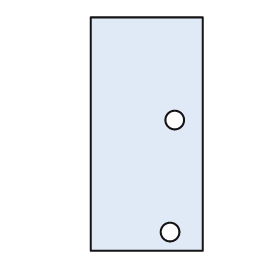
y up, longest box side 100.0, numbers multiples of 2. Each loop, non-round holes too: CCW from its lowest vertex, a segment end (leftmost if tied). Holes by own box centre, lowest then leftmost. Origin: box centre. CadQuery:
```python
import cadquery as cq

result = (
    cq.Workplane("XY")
    .moveTo(-24.0, -50.0)
    .lineTo(24.0, -50.0)
    .lineTo(24.0, 50.0)
    .lineTo(-24.0, 50.0)
    .close()
    .moveTo(10.0, -42.0)
    .circle(4.0)
    .moveTo(12.0, 6.0)
    .circle(4.0)
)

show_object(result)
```